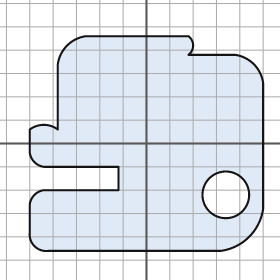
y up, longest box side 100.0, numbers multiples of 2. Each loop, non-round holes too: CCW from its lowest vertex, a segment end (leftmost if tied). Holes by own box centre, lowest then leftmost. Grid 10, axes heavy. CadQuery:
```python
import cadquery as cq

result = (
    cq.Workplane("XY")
    .moveTo(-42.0, -46.0)
    .lineTo(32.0, -46.0)
    .threePointArc((44.0, -40.0), (50.0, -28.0))
    .lineTo(50.0, 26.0)
    .threePointArc((46.0, 34.0), (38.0, 38.0))
    .lineTo(18.0, 38.0)
    .threePointArc((20.0, 42.0), (18.0, 46.0))
    .lineTo(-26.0, 46.0)
    .threePointArc((-34.0, 42.0), (-38.0, 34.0))
    .lineTo(-38.0, 6.0)
    .threePointArc((-44.0, 8.0), (-50.0, 6.0))
    .lineTo(-50.0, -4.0)
    .threePointArc((-48.0, -8.0), (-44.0, -10.0))
    .lineTo(-12.0, -10.0)
    .lineTo(-12.0, -20.0)
    .lineTo(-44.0, -20.0)
    .threePointArc((-48.0, -22.0), (-50.0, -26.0))
    .lineTo(-50.0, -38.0)
    .threePointArc((-48.0, -44.0), (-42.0, -46.0))
    .close()
    .moveTo(34.0, -22.0)
    .circle(10.0)
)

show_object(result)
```